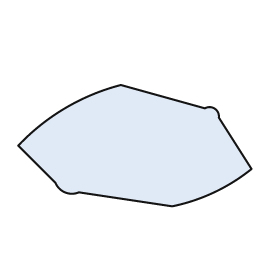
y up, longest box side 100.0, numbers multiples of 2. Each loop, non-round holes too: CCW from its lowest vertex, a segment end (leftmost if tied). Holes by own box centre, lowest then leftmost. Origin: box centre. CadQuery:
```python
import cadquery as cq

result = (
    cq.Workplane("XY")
    .moveTo(16.0, -26.0)
    .threePointArc((34.0, -20.0), (50.0, -10.0))
    .lineTo(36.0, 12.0)
    .threePointArc((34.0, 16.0), (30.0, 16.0))
    .lineTo(-6.0, 26.0)
    .threePointArc((-30.0, 16.0), (-50.0, 0.0))
    .lineTo(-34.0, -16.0)
    .threePointArc((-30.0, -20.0), (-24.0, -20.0))
    .close()
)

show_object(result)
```